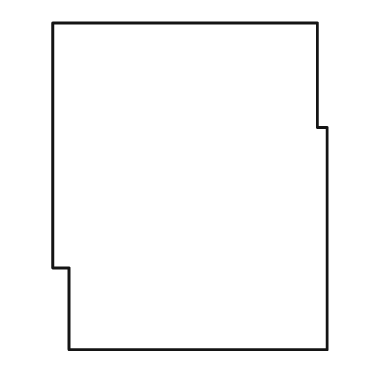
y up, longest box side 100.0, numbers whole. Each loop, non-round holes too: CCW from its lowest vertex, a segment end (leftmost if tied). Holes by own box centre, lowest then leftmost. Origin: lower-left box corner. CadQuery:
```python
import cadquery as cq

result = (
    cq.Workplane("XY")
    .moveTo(5.0, 0.0)
    .lineTo(84.0, 0.0)
    .lineTo(84.0, 68.0)
    .lineTo(81.0, 68.0)
    .lineTo(81.0, 100.0)
    .lineTo(0.0, 100.0)
    .lineTo(0.0, 25.0)
    .lineTo(5.0, 25.0)
    .close()
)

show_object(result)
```